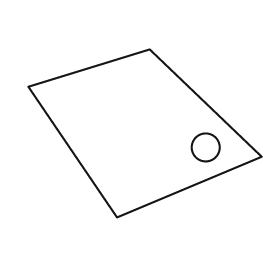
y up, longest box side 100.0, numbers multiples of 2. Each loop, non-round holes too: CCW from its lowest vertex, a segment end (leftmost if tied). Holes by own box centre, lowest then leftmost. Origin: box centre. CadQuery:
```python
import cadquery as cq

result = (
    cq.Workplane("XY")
    .moveTo(-12.0, -36.0)
    .lineTo(50.0, -10.0)
    .lineTo(2.0, 36.0)
    .lineTo(-50.0, 20.0)
    .close()
    .moveTo(26.0, -6.0)
    .circle(6.0)
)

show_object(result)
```